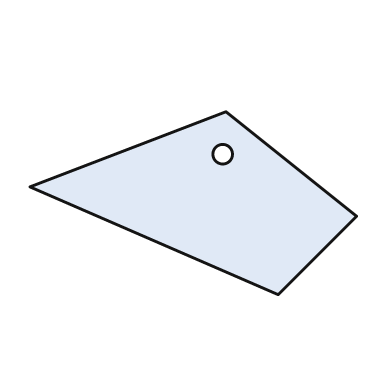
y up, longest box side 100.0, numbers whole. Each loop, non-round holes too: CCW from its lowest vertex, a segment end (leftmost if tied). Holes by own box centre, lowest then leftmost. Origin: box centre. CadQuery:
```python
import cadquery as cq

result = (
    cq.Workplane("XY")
    .moveTo(26.0, -28.0)
    .lineTo(50.0, -4.0)
    .lineTo(10.0, 28.0)
    .lineTo(-50.0, 5.0)
    .close()
    .moveTo(9.0, 15.0)
    .circle(3.0)
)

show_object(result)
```